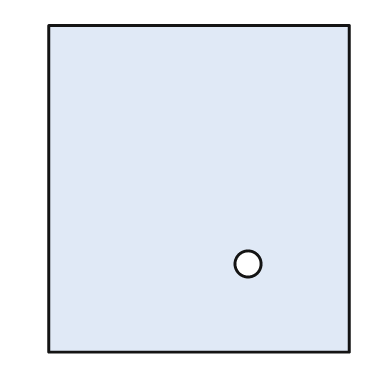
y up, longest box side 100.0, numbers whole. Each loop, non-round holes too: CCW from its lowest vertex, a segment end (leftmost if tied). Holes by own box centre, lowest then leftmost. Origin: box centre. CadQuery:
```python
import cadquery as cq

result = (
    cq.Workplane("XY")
    .moveTo(-46.0, -50.0)
    .lineTo(46.0, -50.0)
    .lineTo(46.0, 50.0)
    .lineTo(-46.0, 50.0)
    .close()
    .moveTo(15.0, -23.0)
    .circle(4.0)
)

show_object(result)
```